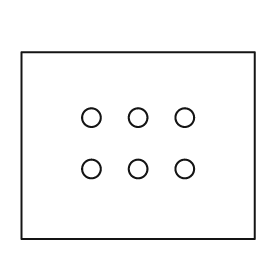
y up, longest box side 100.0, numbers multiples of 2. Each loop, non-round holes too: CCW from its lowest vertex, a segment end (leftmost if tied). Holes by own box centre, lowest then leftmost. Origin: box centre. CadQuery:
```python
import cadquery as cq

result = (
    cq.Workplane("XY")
    .moveTo(-50.0, -40.0)
    .lineTo(50.0, -40.0)
    .lineTo(50.0, 40.0)
    .lineTo(-50.0, 40.0)
    .close()
    .moveTo(-20.0, -10.0)
    .circle(4.0)
    .moveTo(0.0, -10.0)
    .circle(4.0)
    .moveTo(20.0, -10.0)
    .circle(4.0)
    .moveTo(-20.0, 12.0)
    .circle(4.0)
    .moveTo(0.0, 12.0)
    .circle(4.0)
    .moveTo(20.0, 12.0)
    .circle(4.0)
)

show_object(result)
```